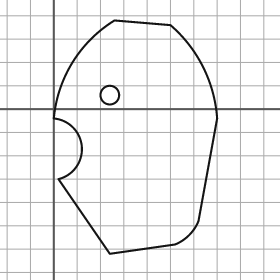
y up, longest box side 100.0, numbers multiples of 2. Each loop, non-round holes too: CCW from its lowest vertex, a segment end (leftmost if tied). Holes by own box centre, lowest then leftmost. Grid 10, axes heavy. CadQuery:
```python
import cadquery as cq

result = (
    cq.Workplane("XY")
    .moveTo(24.0, -62.0)
    .lineTo(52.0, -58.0)
    .threePointArc((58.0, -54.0), (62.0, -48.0))
    .lineTo(70.0, -4.0)
    .threePointArc((64.0, 18.0), (50.0, 36.0))
    .lineTo(26.0, 38.0)
    .threePointArc((8.0, 20.0), (0.0, -4.0))
    .threePointArc((12.0, -16.0), (2.0, -30.0))
    .close()
    .moveTo(24.0, 6.0)
    .circle(4.0)
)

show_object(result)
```